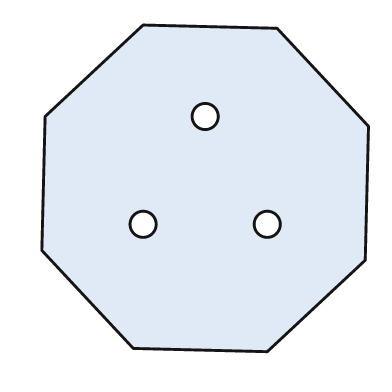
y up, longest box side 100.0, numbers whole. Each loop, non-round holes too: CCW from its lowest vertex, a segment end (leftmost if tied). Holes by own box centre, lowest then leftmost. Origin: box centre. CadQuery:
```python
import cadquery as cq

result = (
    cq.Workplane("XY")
    .moveTo(19.0, -50.0)
    .lineTo(49.0, -22.0)
    .lineTo(50.0, 19.0)
    .lineTo(22.0, 49.0)
    .lineTo(-19.0, 50.0)
    .lineTo(-49.0, 22.0)
    .lineTo(-50.0, -19.0)
    .lineTo(-22.0, -49.0)
    .close()
    .moveTo(-19.0, -11.0)
    .circle(4.0)
    .moveTo(19.0, -11.0)
    .circle(4.0)
    .moveTo(0.0, 22.0)
    .circle(4.0)
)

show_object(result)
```